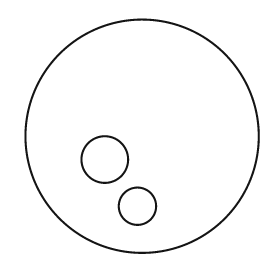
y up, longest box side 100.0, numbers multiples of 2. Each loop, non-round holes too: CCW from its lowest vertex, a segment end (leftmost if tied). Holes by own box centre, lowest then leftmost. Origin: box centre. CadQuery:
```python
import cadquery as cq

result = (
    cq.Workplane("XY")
    .moveTo(0.0, 0.0)
    .circle(50.0)
    .moveTo(-2.0, -30.0)
    .circle(8.0)
    .moveTo(-16.0, -10.0)
    .circle(10.0)
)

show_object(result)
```